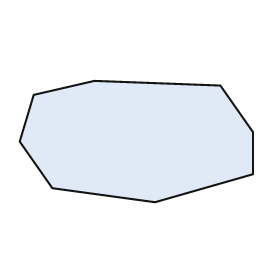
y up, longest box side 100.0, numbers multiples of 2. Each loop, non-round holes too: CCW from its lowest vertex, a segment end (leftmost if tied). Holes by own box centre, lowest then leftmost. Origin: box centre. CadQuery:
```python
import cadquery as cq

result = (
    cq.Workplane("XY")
    .moveTo(8.0, -26.0)
    .lineTo(50.0, -14.0)
    .lineTo(50.0, 4.0)
    .lineTo(36.0, 24.0)
    .lineTo(-18.0, 26.0)
    .lineTo(-44.0, 20.0)
    .lineTo(-50.0, 0.0)
    .lineTo(-36.0, -20.0)
    .close()
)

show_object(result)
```